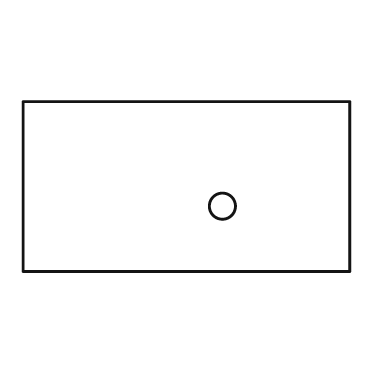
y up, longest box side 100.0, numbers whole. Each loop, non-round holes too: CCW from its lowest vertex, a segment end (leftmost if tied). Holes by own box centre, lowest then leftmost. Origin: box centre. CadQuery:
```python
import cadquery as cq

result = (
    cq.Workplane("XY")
    .moveTo(-50.0, -26.0)
    .lineTo(50.0, -26.0)
    .lineTo(50.0, 26.0)
    .lineTo(-50.0, 26.0)
    .close()
    .moveTo(11.0, -6.0)
    .circle(4.0)
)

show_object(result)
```